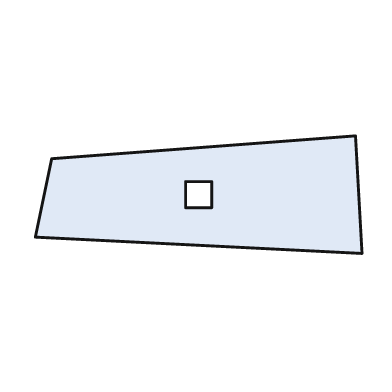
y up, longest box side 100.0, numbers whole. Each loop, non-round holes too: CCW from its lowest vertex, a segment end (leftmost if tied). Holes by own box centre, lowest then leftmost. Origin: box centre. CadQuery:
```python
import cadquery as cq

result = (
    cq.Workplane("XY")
    .moveTo(50.0, -18.0)
    .lineTo(48.0, 18.0)
    .lineTo(-45.0, 11.0)
    .lineTo(-50.0, -13.0)
    .close()
    .moveTo(-4.0, -4.0)
    .lineTo(4.0, -4.0)
    .lineTo(4.0, 4.0)
    .lineTo(-4.0, 4.0)
    .close()
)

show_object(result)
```